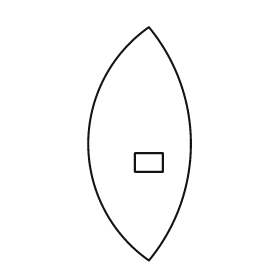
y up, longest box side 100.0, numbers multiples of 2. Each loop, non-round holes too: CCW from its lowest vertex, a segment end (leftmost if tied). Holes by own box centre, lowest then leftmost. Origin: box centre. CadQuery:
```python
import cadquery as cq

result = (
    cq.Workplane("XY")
    .moveTo(4.0, -50.0)
    .threePointArc((22.0, 0.0), (4.0, 50.0))
    .threePointArc((-22.0, 0.0), (4.0, -50.0))
    .close()
    .moveTo(-2.0, -12.0)
    .lineTo(10.0, -12.0)
    .lineTo(10.0, -4.0)
    .lineTo(-2.0, -4.0)
    .close()
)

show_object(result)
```